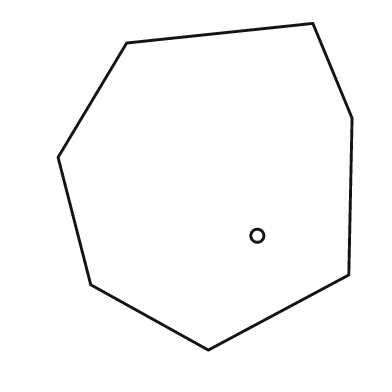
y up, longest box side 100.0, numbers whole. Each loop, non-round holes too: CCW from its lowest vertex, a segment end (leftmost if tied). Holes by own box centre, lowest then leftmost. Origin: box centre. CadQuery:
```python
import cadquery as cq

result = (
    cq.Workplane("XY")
    .moveTo(1.0, -50.0)
    .lineTo(44.0, -27.0)
    .lineTo(45.0, 21.0)
    .lineTo(33.0, 50.0)
    .lineTo(-24.0, 44.0)
    .lineTo(-45.0, 9.0)
    .lineTo(-35.0, -30.0)
    .close()
    .moveTo(16.0, -15.0)
    .circle(2.0)
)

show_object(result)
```